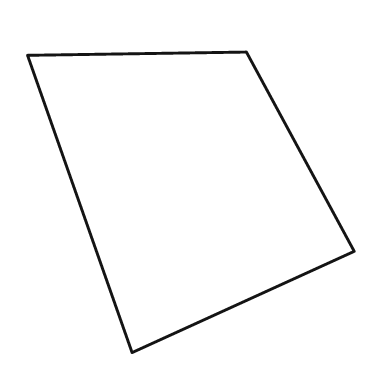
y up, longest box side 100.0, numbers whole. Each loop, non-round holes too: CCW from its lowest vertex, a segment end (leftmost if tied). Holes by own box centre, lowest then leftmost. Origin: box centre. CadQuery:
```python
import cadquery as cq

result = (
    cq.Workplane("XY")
    .moveTo(-18.0, -46.0)
    .lineTo(50.0, -15.0)
    .lineTo(17.0, 46.0)
    .lineTo(-50.0, 45.0)
    .close()
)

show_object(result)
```